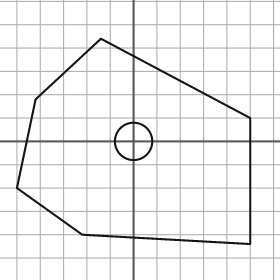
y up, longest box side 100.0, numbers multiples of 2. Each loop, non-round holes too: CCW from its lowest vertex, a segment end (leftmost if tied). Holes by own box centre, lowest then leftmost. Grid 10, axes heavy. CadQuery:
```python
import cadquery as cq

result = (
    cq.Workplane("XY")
    .moveTo(50.0, -44.0)
    .lineTo(50.0, 10.0)
    .lineTo(-14.0, 44.0)
    .lineTo(-42.0, 18.0)
    .lineTo(-50.0, -20.0)
    .lineTo(-22.0, -40.0)
    .close()
    .moveTo(0.0, 0.0)
    .circle(8.0)
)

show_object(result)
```